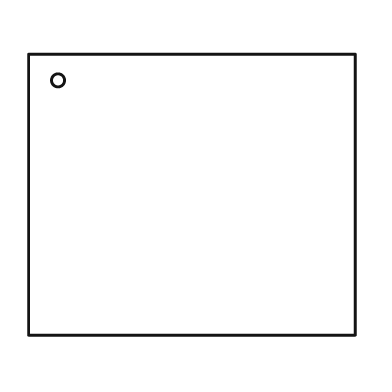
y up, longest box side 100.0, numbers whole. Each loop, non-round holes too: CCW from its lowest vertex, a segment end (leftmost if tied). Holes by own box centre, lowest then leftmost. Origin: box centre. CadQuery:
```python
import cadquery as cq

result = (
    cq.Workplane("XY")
    .moveTo(-50.0, -43.0)
    .lineTo(50.0, -43.0)
    .lineTo(50.0, 43.0)
    .lineTo(-50.0, 43.0)
    .close()
    .moveTo(-41.0, 35.0)
    .circle(2.0)
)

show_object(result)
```